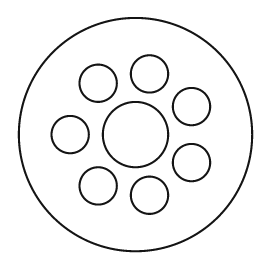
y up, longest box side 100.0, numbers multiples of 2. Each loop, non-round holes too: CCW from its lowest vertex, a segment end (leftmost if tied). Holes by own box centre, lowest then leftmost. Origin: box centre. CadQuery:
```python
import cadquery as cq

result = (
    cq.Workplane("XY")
    .moveTo(0.0, 0.0)
    .circle(50.0)
    .moveTo(6.0, -26.0)
    .circle(8.0)
    .moveTo(-16.0, -22.0)
    .circle(8.0)
    .moveTo(24.0, -12.0)
    .circle(8.0)
    .moveTo(-28.0, 0.0)
    .circle(8.0)
    .moveTo(0.0, 0.0)
    .circle(14.0)
    .moveTo(24.0, 12.0)
    .circle(8.0)
    .moveTo(-16.0, 22.0)
    .circle(8.0)
    .moveTo(6.0, 26.0)
    .circle(8.0)
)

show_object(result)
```